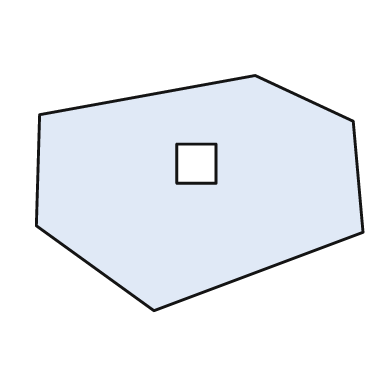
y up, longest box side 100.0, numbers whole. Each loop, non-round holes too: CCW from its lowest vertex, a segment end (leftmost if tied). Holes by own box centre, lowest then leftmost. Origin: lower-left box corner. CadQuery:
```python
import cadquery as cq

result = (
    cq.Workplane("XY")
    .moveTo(36.0, 0.0)
    .lineTo(100.0, 24.0)
    .lineTo(97.0, 58.0)
    .lineTo(67.0, 72.0)
    .lineTo(1.0, 60.0)
    .lineTo(0.0, 26.0)
    .close()
    .moveTo(43.0, 39.0)
    .lineTo(55.0, 39.0)
    .lineTo(55.0, 51.0)
    .lineTo(43.0, 51.0)
    .close()
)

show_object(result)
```